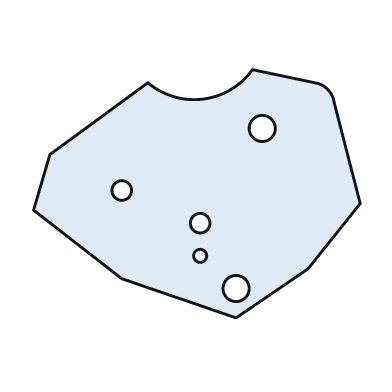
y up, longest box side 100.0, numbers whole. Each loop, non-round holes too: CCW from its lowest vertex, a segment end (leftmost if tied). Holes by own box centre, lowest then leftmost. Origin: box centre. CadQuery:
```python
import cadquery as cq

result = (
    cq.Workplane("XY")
    .moveTo(12.0, -38.0)
    .lineTo(34.0, -23.0)
    .lineTo(50.0, -3.0)
    .lineTo(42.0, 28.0)
    .threePointArc((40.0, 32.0), (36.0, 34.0))
    .lineTo(17.0, 38.0)
    .threePointArc((2.0, 29.0), (-15.0, 34.0))
    .lineTo(-45.0, 12.0)
    .lineTo(-50.0, -5.0)
    .lineTo(-23.0, -26.0)
    .close()
    .moveTo(12.0, -29.0)
    .circle(4.0)
    .moveTo(1.0, -19.0)
    .circle(2.0)
    .moveTo(1.0, -9.0)
    .circle(3.0)
    .moveTo(-23.0, 1.0)
    .circle(3.0)
    .moveTo(20.0, 20.0)
    .circle(4.0)
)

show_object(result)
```